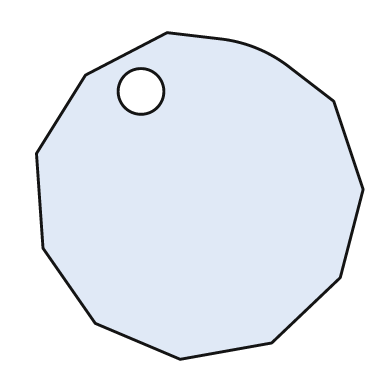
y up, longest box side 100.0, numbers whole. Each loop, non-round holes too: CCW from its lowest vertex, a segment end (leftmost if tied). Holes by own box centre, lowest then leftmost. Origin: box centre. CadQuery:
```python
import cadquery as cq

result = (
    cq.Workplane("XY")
    .moveTo(-6.0, -50.0)
    .lineTo(22.0, -45.0)
    .lineTo(43.0, -25.0)
    .lineTo(50.0, 2.0)
    .lineTo(41.0, 29.0)
    .lineTo(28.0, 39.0)
    .threePointArc((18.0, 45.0), (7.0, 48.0))
    .lineTo(-10.0, 50.0)
    .lineTo(-35.0, 37.0)
    .lineTo(-50.0, 13.0)
    .lineTo(-48.0, -16.0)
    .lineTo(-32.0, -39.0)
    .close()
    .moveTo(-18.0, 32.0)
    .circle(7.0)
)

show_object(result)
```